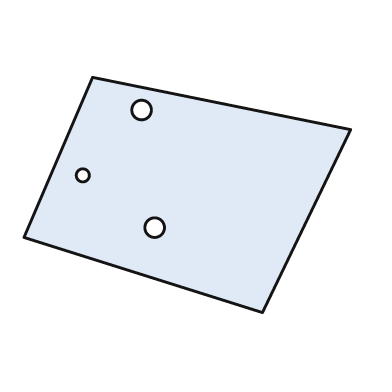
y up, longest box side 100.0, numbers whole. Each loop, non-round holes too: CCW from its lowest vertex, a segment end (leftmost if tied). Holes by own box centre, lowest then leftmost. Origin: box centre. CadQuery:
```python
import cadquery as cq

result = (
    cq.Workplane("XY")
    .moveTo(23.0, -36.0)
    .lineTo(50.0, 20.0)
    .lineTo(-29.0, 36.0)
    .lineTo(-50.0, -13.0)
    .close()
    .moveTo(-10.0, -10.0)
    .circle(3.0)
    .moveTo(-32.0, 6.0)
    .circle(2.0)
    .moveTo(-14.0, 26.0)
    .circle(3.0)
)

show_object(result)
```